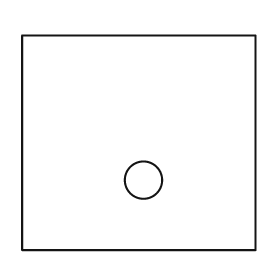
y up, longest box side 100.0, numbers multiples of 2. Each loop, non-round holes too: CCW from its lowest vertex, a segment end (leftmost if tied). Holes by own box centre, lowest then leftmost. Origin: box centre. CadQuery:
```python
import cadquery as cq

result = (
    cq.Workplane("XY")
    .moveTo(-50.0, -46.0)
    .lineTo(50.0, -46.0)
    .lineTo(50.0, 46.0)
    .lineTo(-50.0, 46.0)
    .close()
    .moveTo(2.0, -16.0)
    .circle(8.0)
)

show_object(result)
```